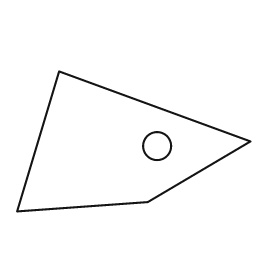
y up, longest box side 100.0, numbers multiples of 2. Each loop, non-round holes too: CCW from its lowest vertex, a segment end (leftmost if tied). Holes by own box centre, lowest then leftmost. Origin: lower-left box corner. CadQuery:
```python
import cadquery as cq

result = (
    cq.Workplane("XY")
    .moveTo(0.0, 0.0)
    .lineTo(56.0, 4.0)
    .lineTo(100.0, 30.0)
    .lineTo(18.0, 60.0)
    .close()
    .moveTo(60.0, 28.0)
    .circle(6.0)
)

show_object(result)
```